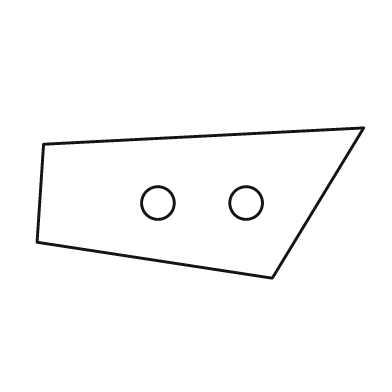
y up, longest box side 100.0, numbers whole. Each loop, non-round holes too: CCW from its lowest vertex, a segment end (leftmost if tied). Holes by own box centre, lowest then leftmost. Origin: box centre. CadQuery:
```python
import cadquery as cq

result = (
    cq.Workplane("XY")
    .moveTo(22.0, -23.0)
    .lineTo(50.0, 23.0)
    .lineTo(-48.0, 18.0)
    .lineTo(-50.0, -12.0)
    .close()
    .moveTo(-13.0, 0.0)
    .circle(5.0)
    .moveTo(14.0, 0.0)
    .circle(5.0)
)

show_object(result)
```